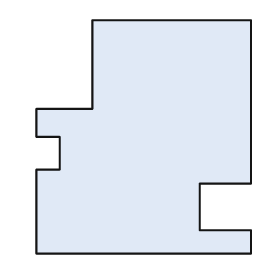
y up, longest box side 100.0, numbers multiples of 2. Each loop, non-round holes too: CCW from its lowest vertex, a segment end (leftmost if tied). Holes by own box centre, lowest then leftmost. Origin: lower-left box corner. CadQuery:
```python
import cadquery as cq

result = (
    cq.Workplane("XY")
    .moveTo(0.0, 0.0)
    .lineTo(92.0, 0.0)
    .lineTo(92.0, 10.0)
    .lineTo(70.0, 10.0)
    .lineTo(70.0, 30.0)
    .lineTo(92.0, 30.0)
    .lineTo(92.0, 100.0)
    .lineTo(24.0, 100.0)
    .lineTo(24.0, 62.0)
    .lineTo(0.0, 62.0)
    .lineTo(0.0, 50.0)
    .lineTo(10.0, 50.0)
    .lineTo(10.0, 36.0)
    .lineTo(0.0, 36.0)
    .close()
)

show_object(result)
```